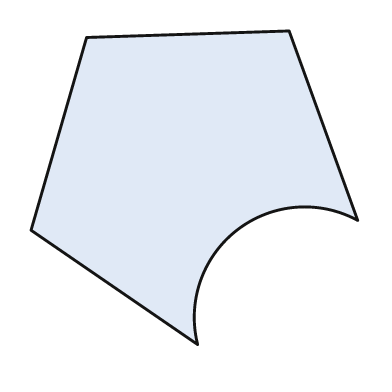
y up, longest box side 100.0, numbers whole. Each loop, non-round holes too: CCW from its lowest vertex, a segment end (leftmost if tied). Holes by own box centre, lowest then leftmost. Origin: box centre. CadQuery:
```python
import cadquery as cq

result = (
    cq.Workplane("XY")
    .moveTo(1.0, -48.0)
    .threePointArc((13.0, -13.0), (50.0, -10.0))
    .lineTo(29.0, 48.0)
    .lineTo(-33.0, 46.0)
    .lineTo(-50.0, -13.0)
    .close()
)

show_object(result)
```